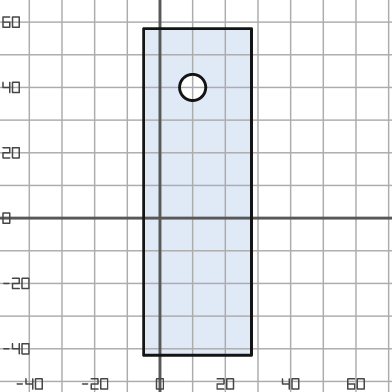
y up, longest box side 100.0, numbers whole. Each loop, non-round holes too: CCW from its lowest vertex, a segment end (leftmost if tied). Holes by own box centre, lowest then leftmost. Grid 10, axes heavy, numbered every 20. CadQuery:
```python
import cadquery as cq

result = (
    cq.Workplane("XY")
    .moveTo(-5.0, -42.0)
    .lineTo(28.0, -42.0)
    .lineTo(28.0, 58.0)
    .lineTo(-5.0, 58.0)
    .close()
    .moveTo(10.0, 40.0)
    .circle(4.0)
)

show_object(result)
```